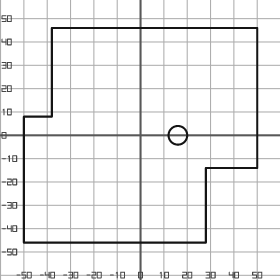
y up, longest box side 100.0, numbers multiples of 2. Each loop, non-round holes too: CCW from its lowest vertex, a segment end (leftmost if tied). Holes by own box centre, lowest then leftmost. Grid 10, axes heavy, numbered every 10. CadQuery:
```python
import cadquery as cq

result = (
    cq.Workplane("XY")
    .moveTo(-50.0, -46.0)
    .lineTo(28.0, -46.0)
    .lineTo(28.0, -14.0)
    .lineTo(50.0, -14.0)
    .lineTo(50.0, 46.0)
    .lineTo(-38.0, 46.0)
    .lineTo(-38.0, 8.0)
    .lineTo(-50.0, 8.0)
    .close()
    .moveTo(16.0, 0.0)
    .circle(4.0)
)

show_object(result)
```